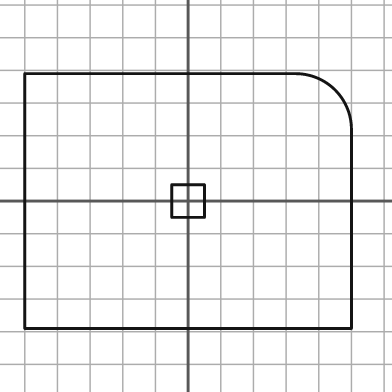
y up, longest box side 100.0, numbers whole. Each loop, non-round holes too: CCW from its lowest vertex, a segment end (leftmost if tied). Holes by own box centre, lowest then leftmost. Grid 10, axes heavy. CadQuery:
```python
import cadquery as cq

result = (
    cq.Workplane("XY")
    .moveTo(-50.0, -39.0)
    .lineTo(50.0, -39.0)
    .lineTo(50.0, 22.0)
    .threePointArc((45.0, 34.0), (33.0, 39.0))
    .lineTo(-50.0, 39.0)
    .close()
    .moveTo(-5.0, -5.0)
    .lineTo(5.0, -5.0)
    .lineTo(5.0, 5.0)
    .lineTo(-5.0, 5.0)
    .close()
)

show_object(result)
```